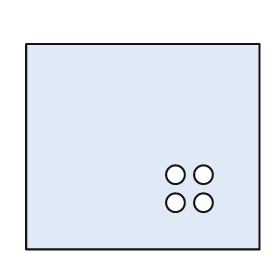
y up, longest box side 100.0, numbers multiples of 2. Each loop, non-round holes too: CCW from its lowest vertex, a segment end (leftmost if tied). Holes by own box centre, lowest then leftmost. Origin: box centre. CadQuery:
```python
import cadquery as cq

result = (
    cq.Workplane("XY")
    .moveTo(-50.0, -44.0)
    .lineTo(50.0, -44.0)
    .lineTo(50.0, 44.0)
    .lineTo(-50.0, 44.0)
    .close()
    .moveTo(14.0, -24.0)
    .circle(4.0)
    .moveTo(26.0, -24.0)
    .circle(4.0)
    .moveTo(14.0, -12.0)
    .circle(4.0)
    .moveTo(26.0, -12.0)
    .circle(4.0)
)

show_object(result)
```